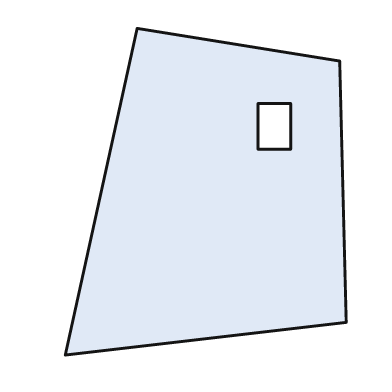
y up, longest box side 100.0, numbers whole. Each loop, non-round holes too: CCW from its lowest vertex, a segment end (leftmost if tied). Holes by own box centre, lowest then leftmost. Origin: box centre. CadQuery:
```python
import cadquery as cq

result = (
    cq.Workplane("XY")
    .moveTo(-43.0, -50.0)
    .lineTo(43.0, -40.0)
    .lineTo(41.0, 40.0)
    .lineTo(-21.0, 50.0)
    .close()
    .moveTo(16.0, 13.0)
    .lineTo(26.0, 13.0)
    .lineTo(26.0, 27.0)
    .lineTo(16.0, 27.0)
    .close()
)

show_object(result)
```